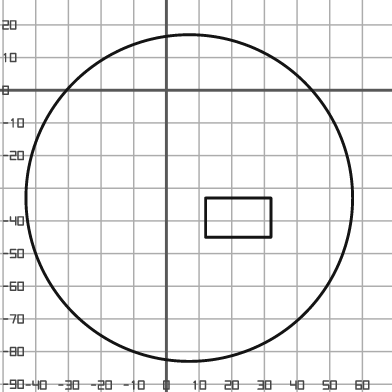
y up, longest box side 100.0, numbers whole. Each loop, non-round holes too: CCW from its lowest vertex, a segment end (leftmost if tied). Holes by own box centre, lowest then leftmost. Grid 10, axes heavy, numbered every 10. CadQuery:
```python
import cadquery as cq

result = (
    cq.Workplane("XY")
    .moveTo(7.0, -33.0)
    .circle(50.0)
    .moveTo(12.0, -45.0)
    .lineTo(32.0, -45.0)
    .lineTo(32.0, -33.0)
    .lineTo(12.0, -33.0)
    .close()
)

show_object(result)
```